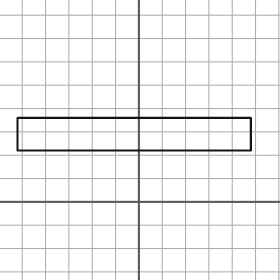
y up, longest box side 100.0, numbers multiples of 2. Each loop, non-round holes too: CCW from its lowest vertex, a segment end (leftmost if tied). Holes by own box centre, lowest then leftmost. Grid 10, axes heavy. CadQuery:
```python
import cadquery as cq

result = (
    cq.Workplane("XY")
    .moveTo(-52.0, 22.0)
    .lineTo(48.0, 22.0)
    .lineTo(48.0, 36.0)
    .lineTo(-52.0, 36.0)
    .close()
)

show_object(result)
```